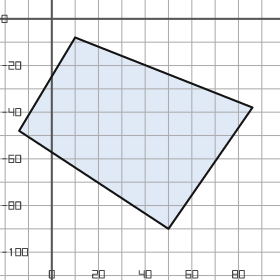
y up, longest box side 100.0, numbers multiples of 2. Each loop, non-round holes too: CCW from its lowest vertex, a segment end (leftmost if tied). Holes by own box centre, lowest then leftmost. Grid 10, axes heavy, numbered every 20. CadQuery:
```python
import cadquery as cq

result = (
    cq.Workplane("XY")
    .moveTo(50.0, -90.0)
    .lineTo(86.0, -38.0)
    .lineTo(10.0, -8.0)
    .lineTo(-14.0, -48.0)
    .close()
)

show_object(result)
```